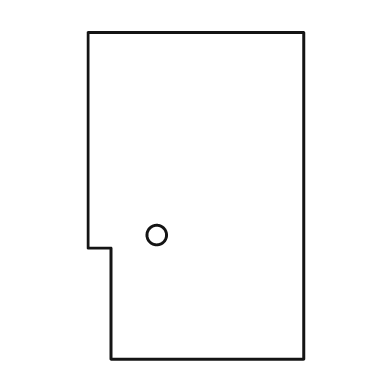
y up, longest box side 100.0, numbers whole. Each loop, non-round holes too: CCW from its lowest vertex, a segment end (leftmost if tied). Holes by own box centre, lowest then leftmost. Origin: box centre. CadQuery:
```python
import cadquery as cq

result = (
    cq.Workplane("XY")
    .moveTo(-26.0, -50.0)
    .lineTo(33.0, -50.0)
    .lineTo(33.0, 50.0)
    .lineTo(-33.0, 50.0)
    .lineTo(-33.0, -16.0)
    .lineTo(-26.0, -16.0)
    .close()
    .moveTo(-12.0, -12.0)
    .circle(3.0)
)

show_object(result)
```